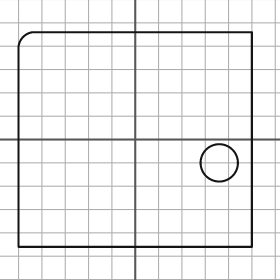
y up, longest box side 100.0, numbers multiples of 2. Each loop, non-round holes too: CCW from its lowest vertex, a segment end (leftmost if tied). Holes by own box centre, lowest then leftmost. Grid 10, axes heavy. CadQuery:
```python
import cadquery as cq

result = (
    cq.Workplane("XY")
    .moveTo(-50.0, -46.0)
    .lineTo(50.0, -46.0)
    .lineTo(50.0, 46.0)
    .lineTo(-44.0, 46.0)
    .threePointArc((-48.0, 44.0), (-50.0, 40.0))
    .close()
    .moveTo(36.0, -10.0)
    .circle(8.0)
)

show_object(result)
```